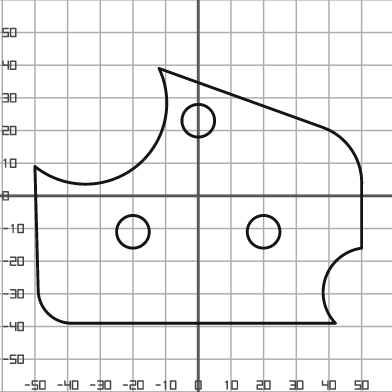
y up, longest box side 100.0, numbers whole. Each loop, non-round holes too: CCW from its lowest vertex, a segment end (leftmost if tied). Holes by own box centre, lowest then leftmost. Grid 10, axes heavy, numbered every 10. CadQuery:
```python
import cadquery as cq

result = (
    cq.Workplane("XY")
    .moveTo(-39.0, -39.0)
    .lineTo(42.0, -39.0)
    .threePointArc((39.0, -25.0), (50.0, -16.0))
    .lineTo(50.0, 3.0)
    .threePointArc((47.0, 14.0), (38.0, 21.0))
    .lineTo(-12.0, 39.0)
    .threePointArc((-19.0, 9.0), (-50.0, 9.0))
    .lineTo(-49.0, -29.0)
    .threePointArc((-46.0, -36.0), (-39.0, -39.0))
    .close()
    .moveTo(-20.0, -11.0)
    .circle(5.0)
    .moveTo(20.0, -11.0)
    .circle(5.0)
    .moveTo(0.0, 23.0)
    .circle(5.0)
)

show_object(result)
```